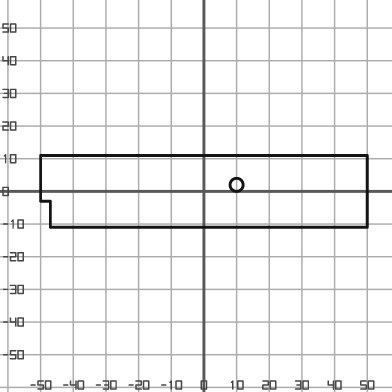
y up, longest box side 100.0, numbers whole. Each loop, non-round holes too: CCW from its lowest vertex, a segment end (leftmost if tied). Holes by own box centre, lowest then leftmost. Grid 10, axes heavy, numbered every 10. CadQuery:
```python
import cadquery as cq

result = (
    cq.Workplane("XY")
    .moveTo(-47.0, -11.0)
    .lineTo(50.0, -11.0)
    .lineTo(50.0, 11.0)
    .lineTo(-50.0, 11.0)
    .lineTo(-50.0, -3.0)
    .lineTo(-47.0, -3.0)
    .close()
    .moveTo(10.0, 2.0)
    .circle(2.0)
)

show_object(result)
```